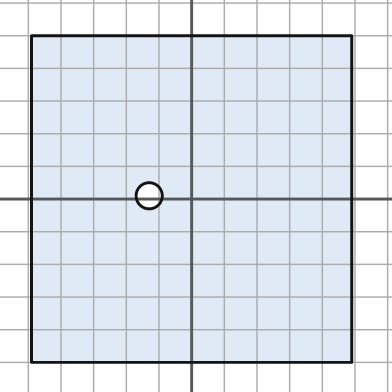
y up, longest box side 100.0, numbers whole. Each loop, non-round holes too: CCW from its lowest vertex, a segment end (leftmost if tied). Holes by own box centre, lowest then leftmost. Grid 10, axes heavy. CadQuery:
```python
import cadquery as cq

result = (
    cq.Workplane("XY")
    .moveTo(-49.0, -50.0)
    .lineTo(49.0, -50.0)
    .lineTo(49.0, 50.0)
    .lineTo(-49.0, 50.0)
    .close()
    .moveTo(-13.0, 1.0)
    .circle(4.0)
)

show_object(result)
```